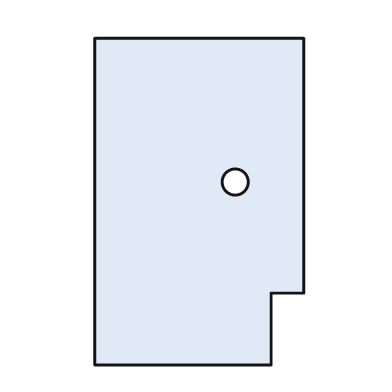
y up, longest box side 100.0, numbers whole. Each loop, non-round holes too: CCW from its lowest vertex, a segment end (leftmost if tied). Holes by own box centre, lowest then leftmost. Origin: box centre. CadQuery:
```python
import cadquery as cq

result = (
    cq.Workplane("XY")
    .moveTo(-32.0, -50.0)
    .lineTo(22.0, -50.0)
    .lineTo(22.0, -28.0)
    .lineTo(32.0, -28.0)
    .lineTo(32.0, 50.0)
    .lineTo(-32.0, 50.0)
    .close()
    .moveTo(11.0, 6.0)
    .circle(4.0)
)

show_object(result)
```